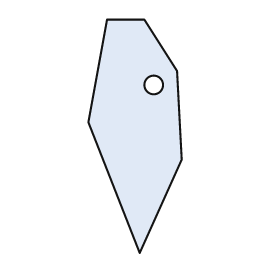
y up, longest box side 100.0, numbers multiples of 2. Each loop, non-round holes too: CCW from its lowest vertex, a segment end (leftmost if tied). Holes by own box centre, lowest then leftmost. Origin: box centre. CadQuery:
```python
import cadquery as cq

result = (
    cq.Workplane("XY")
    .moveTo(2.0, -50.0)
    .lineTo(20.0, -10.0)
    .lineTo(18.0, 28.0)
    .lineTo(4.0, 50.0)
    .lineTo(-12.0, 50.0)
    .lineTo(-20.0, 6.0)
    .close()
    .moveTo(8.0, 22.0)
    .circle(4.0)
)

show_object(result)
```